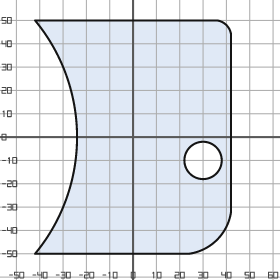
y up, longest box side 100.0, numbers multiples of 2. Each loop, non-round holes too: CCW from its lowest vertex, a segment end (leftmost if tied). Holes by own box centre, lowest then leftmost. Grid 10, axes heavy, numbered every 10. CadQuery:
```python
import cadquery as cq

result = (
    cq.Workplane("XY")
    .moveTo(-42.0, -50.0)
    .lineTo(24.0, -50.0)
    .threePointArc((36.0, -44.0), (42.0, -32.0))
    .lineTo(42.0, 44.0)
    .threePointArc((40.0, 48.0), (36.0, 50.0))
    .lineTo(-42.0, 50.0)
    .threePointArc((-24.0, 0.0), (-42.0, -50.0))
    .close()
    .moveTo(30.0, -10.0)
    .circle(8.0)
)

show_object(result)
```